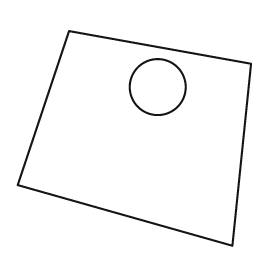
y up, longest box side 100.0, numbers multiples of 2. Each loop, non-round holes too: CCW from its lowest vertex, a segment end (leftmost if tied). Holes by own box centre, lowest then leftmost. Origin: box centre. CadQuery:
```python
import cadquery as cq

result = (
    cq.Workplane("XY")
    .moveTo(42.0, -46.0)
    .lineTo(50.0, 32.0)
    .lineTo(-28.0, 46.0)
    .lineTo(-50.0, -20.0)
    .close()
    .moveTo(10.0, 22.0)
    .circle(12.0)
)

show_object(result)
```